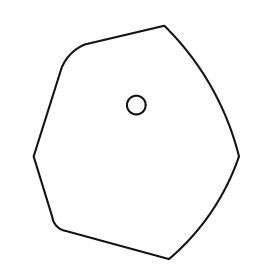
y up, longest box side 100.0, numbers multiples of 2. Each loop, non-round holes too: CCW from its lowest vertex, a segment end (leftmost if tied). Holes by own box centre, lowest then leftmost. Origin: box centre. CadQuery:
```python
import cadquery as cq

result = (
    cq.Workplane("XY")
    .moveTo(14.0, -50.0)
    .threePointArc((32.0, -30.0), (44.0, -6.0))
    .threePointArc((32.0, 24.0), (12.0, 50.0))
    .lineTo(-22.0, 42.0)
    .threePointArc((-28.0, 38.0), (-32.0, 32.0))
    .lineTo(-44.0, -6.0)
    .lineTo(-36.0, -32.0)
    .threePointArc((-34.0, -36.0), (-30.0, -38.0))
    .close()
    .moveTo(0.0, 16.0)
    .circle(4.0)
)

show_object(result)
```